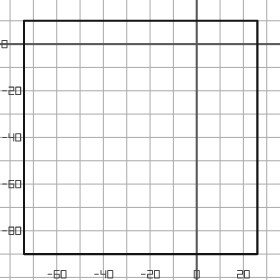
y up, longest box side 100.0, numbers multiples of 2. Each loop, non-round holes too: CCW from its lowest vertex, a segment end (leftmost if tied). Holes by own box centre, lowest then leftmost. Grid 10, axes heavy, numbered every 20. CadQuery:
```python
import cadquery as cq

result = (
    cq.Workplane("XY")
    .moveTo(-74.0, -90.0)
    .lineTo(26.0, -90.0)
    .lineTo(26.0, 10.0)
    .lineTo(-74.0, 10.0)
    .close()
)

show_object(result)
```